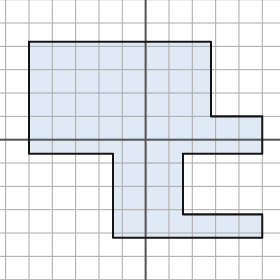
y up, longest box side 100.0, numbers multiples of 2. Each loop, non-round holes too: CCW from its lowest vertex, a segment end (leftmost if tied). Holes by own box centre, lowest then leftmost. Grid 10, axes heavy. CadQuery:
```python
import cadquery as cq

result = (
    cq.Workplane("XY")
    .moveTo(-14.0, -42.0)
    .lineTo(50.0, -42.0)
    .lineTo(50.0, -32.0)
    .lineTo(16.0, -32.0)
    .lineTo(16.0, -6.0)
    .lineTo(50.0, -6.0)
    .lineTo(50.0, 10.0)
    .lineTo(28.0, 10.0)
    .lineTo(28.0, 42.0)
    .lineTo(-50.0, 42.0)
    .lineTo(-50.0, -6.0)
    .lineTo(-14.0, -6.0)
    .close()
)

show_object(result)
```